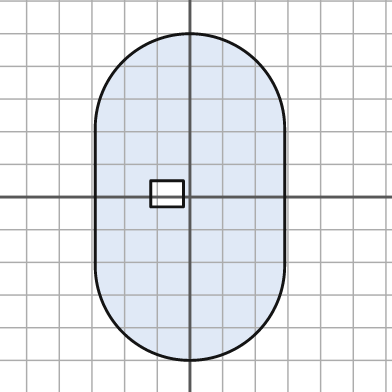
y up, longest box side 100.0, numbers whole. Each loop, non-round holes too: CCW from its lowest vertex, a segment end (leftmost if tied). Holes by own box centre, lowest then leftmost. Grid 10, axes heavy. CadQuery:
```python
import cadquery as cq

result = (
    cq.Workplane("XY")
    .moveTo(-29.0, -21.0)
    .threePointArc((0.0, -50.0), (29.0, -21.0))
    .lineTo(29.0, 21.0)
    .threePointArc((0.0, 50.0), (-29.0, 21.0))
    .close()
    .moveTo(-12.0, -3.0)
    .lineTo(-2.0, -3.0)
    .lineTo(-2.0, 5.0)
    .lineTo(-12.0, 5.0)
    .close()
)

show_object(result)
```